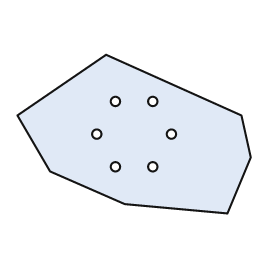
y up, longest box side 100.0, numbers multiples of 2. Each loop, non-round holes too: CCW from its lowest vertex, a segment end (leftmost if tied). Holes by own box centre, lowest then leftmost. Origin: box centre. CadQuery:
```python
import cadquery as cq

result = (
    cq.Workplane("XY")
    .moveTo(40.0, -34.0)
    .lineTo(50.0, -10.0)
    .lineTo(46.0, 8.0)
    .lineTo(-12.0, 34.0)
    .lineTo(-50.0, 8.0)
    .lineTo(-36.0, -16.0)
    .lineTo(-4.0, -30.0)
    .close()
    .moveTo(-8.0, -14.0)
    .circle(2.0)
    .moveTo(8.0, -14.0)
    .circle(2.0)
    .moveTo(-16.0, 0.0)
    .circle(2.0)
    .moveTo(16.0, 0.0)
    .circle(2.0)
    .moveTo(-8.0, 14.0)
    .circle(2.0)
    .moveTo(8.0, 14.0)
    .circle(2.0)
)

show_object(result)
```